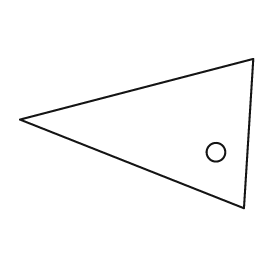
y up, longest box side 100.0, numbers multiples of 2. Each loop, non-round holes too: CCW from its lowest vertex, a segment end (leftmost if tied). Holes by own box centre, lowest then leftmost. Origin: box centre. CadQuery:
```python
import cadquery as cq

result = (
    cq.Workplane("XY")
    .moveTo(46.0, -32.0)
    .lineTo(50.0, 32.0)
    .lineTo(-50.0, 6.0)
    .close()
    .moveTo(34.0, -8.0)
    .circle(4.0)
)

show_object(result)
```